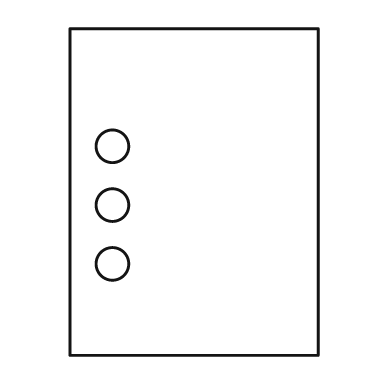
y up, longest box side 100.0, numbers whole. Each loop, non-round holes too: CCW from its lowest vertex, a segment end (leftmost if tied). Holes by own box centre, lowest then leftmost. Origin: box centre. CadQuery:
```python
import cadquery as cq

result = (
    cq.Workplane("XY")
    .moveTo(-38.0, -50.0)
    .lineTo(38.0, -50.0)
    .lineTo(38.0, 50.0)
    .lineTo(-38.0, 50.0)
    .close()
    .moveTo(-25.0, -22.0)
    .circle(5.0)
    .moveTo(-25.0, -4.0)
    .circle(5.0)
    .moveTo(-25.0, 14.0)
    .circle(5.0)
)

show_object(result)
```